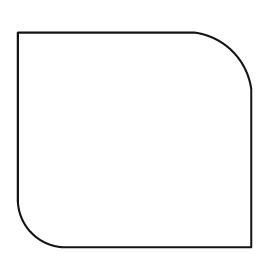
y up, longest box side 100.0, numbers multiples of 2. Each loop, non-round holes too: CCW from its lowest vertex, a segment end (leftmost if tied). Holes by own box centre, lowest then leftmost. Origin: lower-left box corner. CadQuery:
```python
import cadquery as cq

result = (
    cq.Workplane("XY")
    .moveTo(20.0, 0.0)
    .lineTo(100.0, 0.0)
    .lineTo(100.0, 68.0)
    .threePointArc((92.0, 84.0), (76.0, 92.0))
    .lineTo(0.0, 92.0)
    .lineTo(0.0, 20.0)
    .threePointArc((6.0, 6.0), (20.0, 0.0))
    .close()
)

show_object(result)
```